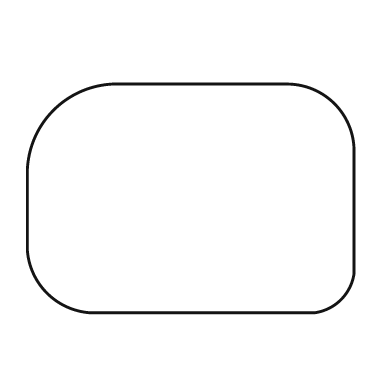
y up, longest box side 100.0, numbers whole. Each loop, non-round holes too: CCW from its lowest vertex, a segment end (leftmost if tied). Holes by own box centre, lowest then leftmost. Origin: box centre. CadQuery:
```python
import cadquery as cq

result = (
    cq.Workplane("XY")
    .moveTo(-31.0, -35.0)
    .lineTo(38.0, -35.0)
    .threePointArc((46.0, -31.0), (50.0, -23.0))
    .lineTo(50.0, 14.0)
    .threePointArc((44.0, 29.0), (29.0, 35.0))
    .lineTo(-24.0, 35.0)
    .threePointArc((-42.0, 27.0), (-50.0, 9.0))
    .lineTo(-50.0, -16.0)
    .threePointArc((-44.0, -29.0), (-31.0, -35.0))
    .close()
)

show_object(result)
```